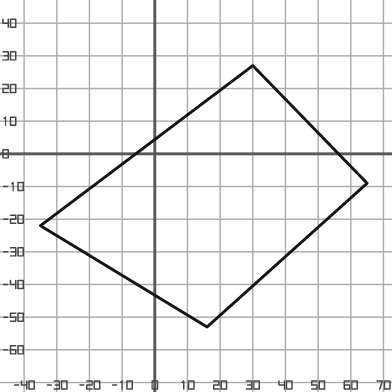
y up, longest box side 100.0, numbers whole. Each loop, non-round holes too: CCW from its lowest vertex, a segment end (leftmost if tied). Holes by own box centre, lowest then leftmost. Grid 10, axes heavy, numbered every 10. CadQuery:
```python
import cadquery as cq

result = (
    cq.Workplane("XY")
    .moveTo(16.0, -53.0)
    .lineTo(65.0, -9.0)
    .lineTo(30.0, 27.0)
    .lineTo(-35.0, -22.0)
    .close()
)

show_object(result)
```